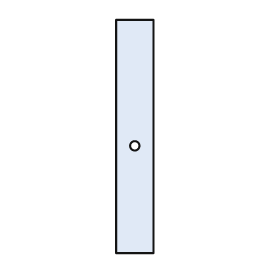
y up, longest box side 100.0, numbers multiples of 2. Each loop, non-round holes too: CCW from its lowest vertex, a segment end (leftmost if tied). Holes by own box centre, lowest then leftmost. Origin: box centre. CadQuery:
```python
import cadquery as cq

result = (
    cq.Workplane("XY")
    .moveTo(-8.0, -50.0)
    .lineTo(8.0, -50.0)
    .lineTo(8.0, 50.0)
    .lineTo(-8.0, 50.0)
    .close()
    .moveTo(0.0, -4.0)
    .circle(2.0)
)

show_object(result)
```